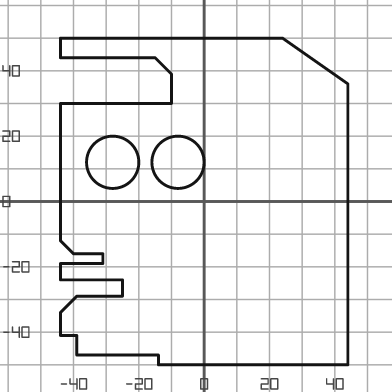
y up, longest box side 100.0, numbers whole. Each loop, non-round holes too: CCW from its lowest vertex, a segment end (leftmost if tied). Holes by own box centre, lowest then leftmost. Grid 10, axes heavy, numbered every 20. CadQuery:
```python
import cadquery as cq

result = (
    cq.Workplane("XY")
    .moveTo(-14.0, -50.0)
    .lineTo(44.0, -50.0)
    .lineTo(44.0, 36.0)
    .lineTo(24.0, 50.0)
    .lineTo(-44.0, 50.0)
    .lineTo(-44.0, 44.0)
    .lineTo(-15.0, 44.0)
    .lineTo(-10.0, 39.0)
    .lineTo(-10.0, 30.0)
    .lineTo(-44.0, 30.0)
    .lineTo(-44.0, -12.0)
    .lineTo(-40.0, -16.0)
    .lineTo(-31.0, -16.0)
    .lineTo(-31.0, -19.0)
    .lineTo(-44.0, -19.0)
    .lineTo(-44.0, -24.0)
    .lineTo(-25.0, -24.0)
    .lineTo(-25.0, -29.0)
    .lineTo(-39.0, -29.0)
    .lineTo(-44.0, -34.0)
    .lineTo(-44.0, -41.0)
    .lineTo(-39.0, -41.0)
    .lineTo(-39.0, -47.0)
    .lineTo(-14.0, -47.0)
    .close()
    .moveTo(-28.0, 12.0)
    .circle(8.0)
    .moveTo(-8.0, 12.0)
    .circle(8.0)
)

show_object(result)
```